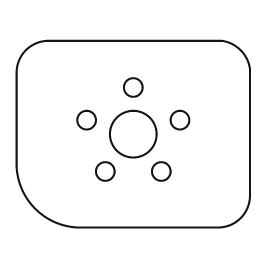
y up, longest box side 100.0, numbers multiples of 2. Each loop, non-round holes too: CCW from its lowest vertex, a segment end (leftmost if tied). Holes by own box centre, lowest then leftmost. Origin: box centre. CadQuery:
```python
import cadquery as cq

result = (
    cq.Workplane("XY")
    .moveTo(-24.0, -40.0)
    .lineTo(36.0, -40.0)
    .threePointArc((46.0, -36.0), (50.0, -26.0))
    .lineTo(50.0, 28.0)
    .threePointArc((46.0, 36.0), (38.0, 40.0))
    .lineTo(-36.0, 40.0)
    .threePointArc((-46.0, 36.0), (-50.0, 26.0))
    .lineTo(-50.0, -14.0)
    .threePointArc((-42.0, -32.0), (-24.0, -40.0))
    .close()
    .moveTo(-12.0, -16.0)
    .circle(4.0)
    .moveTo(12.0, -16.0)
    .circle(4.0)
    .moveTo(0.0, 0.0)
    .circle(10.0)
    .moveTo(-20.0, 6.0)
    .circle(4.0)
    .moveTo(20.0, 6.0)
    .circle(4.0)
    .moveTo(0.0, 20.0)
    .circle(4.0)
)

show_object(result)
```